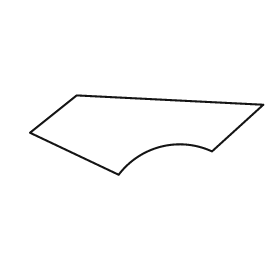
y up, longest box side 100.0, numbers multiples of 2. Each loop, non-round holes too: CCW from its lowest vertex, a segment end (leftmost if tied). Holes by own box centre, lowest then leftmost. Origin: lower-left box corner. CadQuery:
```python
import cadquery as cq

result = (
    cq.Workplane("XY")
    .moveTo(38.0, 0.0)
    .threePointArc((56.0, 12.0), (78.0, 10.0))
    .lineTo(100.0, 30.0)
    .lineTo(20.0, 34.0)
    .lineTo(0.0, 18.0)
    .close()
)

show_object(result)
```